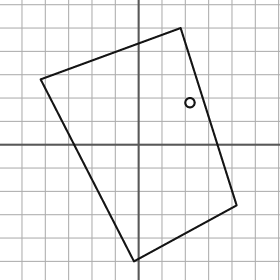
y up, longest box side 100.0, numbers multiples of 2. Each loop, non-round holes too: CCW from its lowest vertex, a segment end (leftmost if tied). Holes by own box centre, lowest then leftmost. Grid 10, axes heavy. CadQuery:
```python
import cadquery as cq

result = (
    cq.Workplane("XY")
    .moveTo(-2.0, -50.0)
    .lineTo(42.0, -26.0)
    .lineTo(18.0, 50.0)
    .lineTo(-42.0, 28.0)
    .close()
    .moveTo(22.0, 18.0)
    .circle(2.0)
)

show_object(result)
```